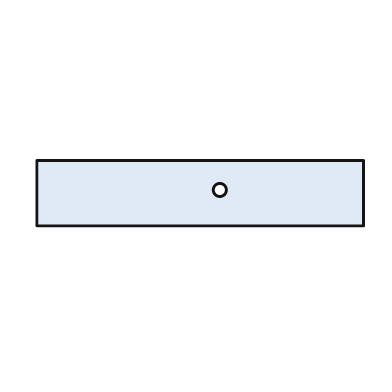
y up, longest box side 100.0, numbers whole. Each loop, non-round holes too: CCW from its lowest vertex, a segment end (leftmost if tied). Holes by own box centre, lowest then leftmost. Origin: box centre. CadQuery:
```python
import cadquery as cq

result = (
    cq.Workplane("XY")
    .moveTo(-50.0, -10.0)
    .lineTo(50.0, -10.0)
    .lineTo(50.0, 10.0)
    .lineTo(-50.0, 10.0)
    .close()
    .moveTo(6.0, 1.0)
    .circle(2.0)
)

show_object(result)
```